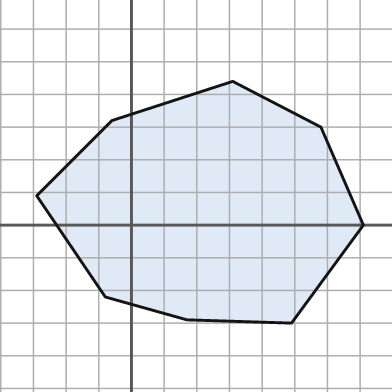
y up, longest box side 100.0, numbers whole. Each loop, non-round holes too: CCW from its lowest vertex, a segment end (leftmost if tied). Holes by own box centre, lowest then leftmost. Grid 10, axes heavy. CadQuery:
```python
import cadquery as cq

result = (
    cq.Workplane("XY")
    .moveTo(49.0, -30.0)
    .lineTo(71.0, 0.0)
    .lineTo(58.0, 30.0)
    .lineTo(31.0, 44.0)
    .lineTo(-6.0, 32.0)
    .lineTo(-29.0, 9.0)
    .lineTo(-8.0, -22.0)
    .lineTo(17.0, -29.0)
    .close()
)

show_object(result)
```